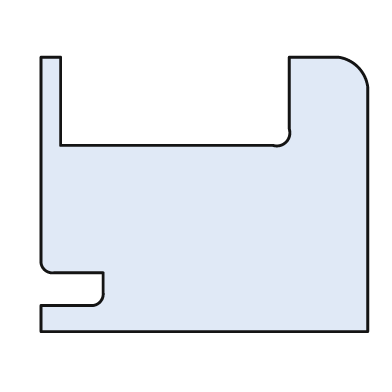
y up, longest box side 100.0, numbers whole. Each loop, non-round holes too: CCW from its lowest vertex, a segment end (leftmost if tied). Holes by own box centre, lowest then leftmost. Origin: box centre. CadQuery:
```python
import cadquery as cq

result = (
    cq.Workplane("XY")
    .moveTo(-50.0, -42.0)
    .lineTo(50.0, -42.0)
    .lineTo(50.0, 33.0)
    .threePointArc((47.0, 39.0), (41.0, 42.0))
    .lineTo(26.0, 42.0)
    .lineTo(26.0, 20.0)
    .threePointArc((25.0, 16.0), (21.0, 15.0))
    .lineTo(-44.0, 15.0)
    .lineTo(-44.0, 42.0)
    .lineTo(-50.0, 42.0)
    .lineTo(-50.0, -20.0)
    .threePointArc((-49.0, -23.0), (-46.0, -24.0))
    .lineTo(-31.0, -24.0)
    .lineTo(-31.0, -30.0)
    .threePointArc((-32.0, -33.0), (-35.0, -34.0))
    .lineTo(-50.0, -34.0)
    .close()
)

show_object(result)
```